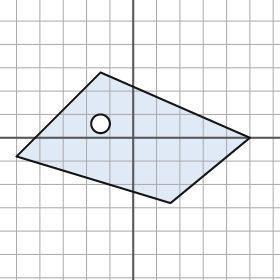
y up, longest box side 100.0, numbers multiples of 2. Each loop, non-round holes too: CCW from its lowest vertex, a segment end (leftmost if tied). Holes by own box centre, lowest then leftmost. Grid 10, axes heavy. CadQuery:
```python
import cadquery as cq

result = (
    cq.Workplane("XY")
    .moveTo(16.0, -28.0)
    .lineTo(50.0, 0.0)
    .lineTo(-14.0, 28.0)
    .lineTo(-50.0, -8.0)
    .close()
    .moveTo(-14.0, 6.0)
    .circle(4.0)
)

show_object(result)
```